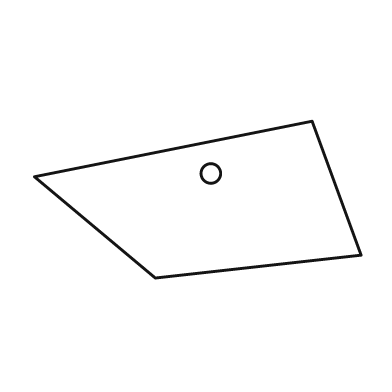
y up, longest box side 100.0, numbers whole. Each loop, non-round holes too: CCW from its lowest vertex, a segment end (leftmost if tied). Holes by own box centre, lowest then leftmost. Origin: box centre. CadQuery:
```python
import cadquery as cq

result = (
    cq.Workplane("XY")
    .moveTo(-13.0, -24.0)
    .lineTo(50.0, -17.0)
    .lineTo(35.0, 24.0)
    .lineTo(-50.0, 7.0)
    .close()
    .moveTo(4.0, 8.0)
    .circle(3.0)
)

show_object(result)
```